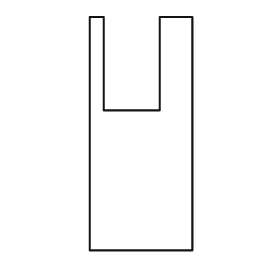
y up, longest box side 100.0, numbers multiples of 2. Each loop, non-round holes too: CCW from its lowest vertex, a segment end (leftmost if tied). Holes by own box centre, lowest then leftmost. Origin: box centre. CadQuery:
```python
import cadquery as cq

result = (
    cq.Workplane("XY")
    .moveTo(-22.0, -50.0)
    .lineTo(22.0, -50.0)
    .lineTo(22.0, 50.0)
    .lineTo(8.0, 50.0)
    .lineTo(8.0, 10.0)
    .lineTo(-16.0, 10.0)
    .lineTo(-16.0, 50.0)
    .lineTo(-22.0, 50.0)
    .close()
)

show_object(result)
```